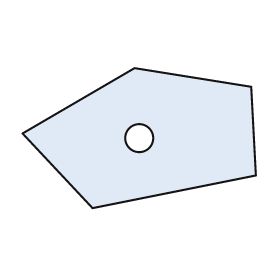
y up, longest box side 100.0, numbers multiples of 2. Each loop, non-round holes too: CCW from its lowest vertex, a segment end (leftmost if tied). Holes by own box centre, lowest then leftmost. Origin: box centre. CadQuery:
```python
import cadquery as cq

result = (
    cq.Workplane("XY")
    .moveTo(-20.0, -30.0)
    .lineTo(50.0, -16.0)
    .lineTo(48.0, 22.0)
    .lineTo(-2.0, 30.0)
    .lineTo(-50.0, 2.0)
    .close()
    .moveTo(0.0, 0.0)
    .circle(6.0)
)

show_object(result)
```